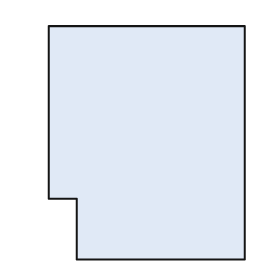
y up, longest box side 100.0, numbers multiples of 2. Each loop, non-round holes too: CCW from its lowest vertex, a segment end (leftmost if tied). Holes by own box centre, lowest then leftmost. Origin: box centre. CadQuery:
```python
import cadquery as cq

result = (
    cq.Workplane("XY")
    .moveTo(-30.0, -50.0)
    .lineTo(42.0, -50.0)
    .lineTo(42.0, 50.0)
    .lineTo(-42.0, 50.0)
    .lineTo(-42.0, -24.0)
    .lineTo(-30.0, -24.0)
    .close()
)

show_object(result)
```